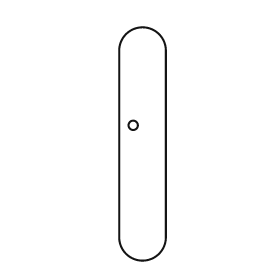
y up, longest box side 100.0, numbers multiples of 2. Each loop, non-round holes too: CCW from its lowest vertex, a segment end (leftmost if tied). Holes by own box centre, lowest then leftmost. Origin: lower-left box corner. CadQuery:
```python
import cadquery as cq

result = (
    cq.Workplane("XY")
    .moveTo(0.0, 10.0)
    .threePointArc((10.0, 0.0), (20.0, 10.0))
    .lineTo(20.0, 90.0)
    .threePointArc((10.0, 100.0), (0.0, 90.0))
    .close()
    .moveTo(6.0, 58.0)
    .circle(2.0)
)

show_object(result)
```